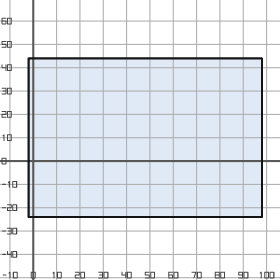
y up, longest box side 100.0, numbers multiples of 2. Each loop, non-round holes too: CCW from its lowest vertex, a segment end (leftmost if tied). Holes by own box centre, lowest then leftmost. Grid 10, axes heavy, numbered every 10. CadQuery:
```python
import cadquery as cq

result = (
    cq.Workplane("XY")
    .moveTo(-2.0, -24.0)
    .lineTo(98.0, -24.0)
    .lineTo(98.0, 44.0)
    .lineTo(-2.0, 44.0)
    .close()
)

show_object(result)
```